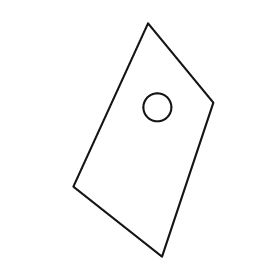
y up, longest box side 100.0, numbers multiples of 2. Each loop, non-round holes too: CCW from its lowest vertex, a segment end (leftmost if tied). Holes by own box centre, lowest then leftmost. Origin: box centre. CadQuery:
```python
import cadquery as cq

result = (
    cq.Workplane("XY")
    .moveTo(8.0, -50.0)
    .lineTo(30.0, 16.0)
    .lineTo(2.0, 50.0)
    .lineTo(-30.0, -20.0)
    .close()
    .moveTo(6.0, 14.0)
    .circle(6.0)
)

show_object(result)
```